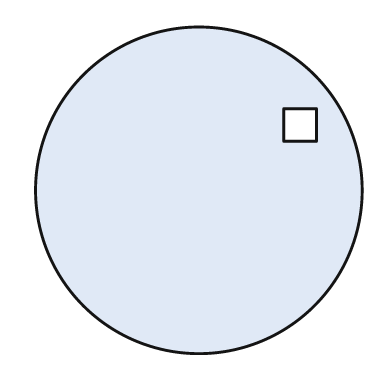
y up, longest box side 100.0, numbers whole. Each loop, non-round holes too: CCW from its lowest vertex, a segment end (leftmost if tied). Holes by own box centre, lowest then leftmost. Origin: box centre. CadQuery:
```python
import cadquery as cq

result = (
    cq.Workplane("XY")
    .moveTo(0.0, 0.0)
    .circle(50.0)
    .moveTo(26.0, 15.0)
    .lineTo(36.0, 15.0)
    .lineTo(36.0, 25.0)
    .lineTo(26.0, 25.0)
    .close()
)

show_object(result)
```